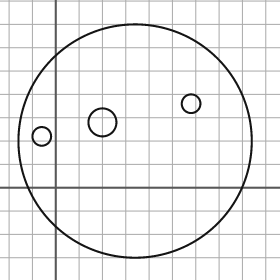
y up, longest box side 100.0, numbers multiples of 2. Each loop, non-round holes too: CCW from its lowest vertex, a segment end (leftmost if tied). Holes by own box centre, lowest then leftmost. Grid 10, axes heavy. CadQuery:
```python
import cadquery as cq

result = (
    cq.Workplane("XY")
    .moveTo(34.0, 20.0)
    .circle(50.0)
    .moveTo(-6.0, 22.0)
    .circle(4.0)
    .moveTo(20.0, 28.0)
    .circle(6.0)
    .moveTo(58.0, 36.0)
    .circle(4.0)
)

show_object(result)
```